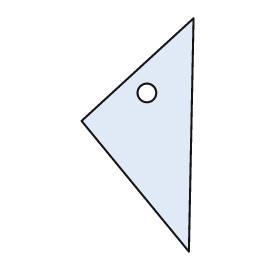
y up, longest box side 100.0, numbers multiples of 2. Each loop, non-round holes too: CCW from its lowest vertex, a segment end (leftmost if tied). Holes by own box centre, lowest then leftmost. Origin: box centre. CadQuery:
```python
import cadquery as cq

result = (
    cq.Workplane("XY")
    .moveTo(22.0, -50.0)
    .lineTo(24.0, 50.0)
    .lineTo(-24.0, 6.0)
    .close()
    .moveTo(4.0, 18.0)
    .circle(4.0)
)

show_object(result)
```